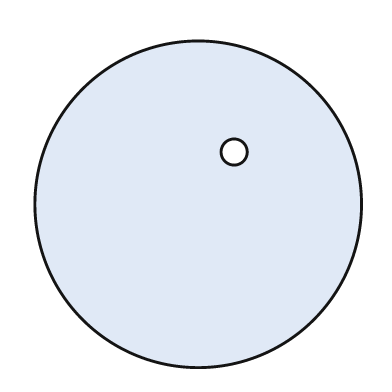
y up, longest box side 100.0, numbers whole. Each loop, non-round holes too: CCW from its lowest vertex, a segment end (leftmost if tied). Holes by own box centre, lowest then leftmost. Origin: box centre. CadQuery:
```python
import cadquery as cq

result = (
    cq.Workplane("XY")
    .moveTo(0.0, 0.0)
    .circle(50.0)
    .moveTo(11.0, 16.0)
    .circle(4.0)
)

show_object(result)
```